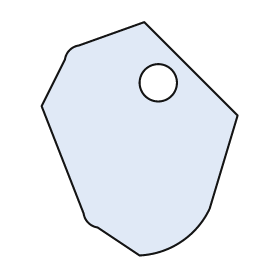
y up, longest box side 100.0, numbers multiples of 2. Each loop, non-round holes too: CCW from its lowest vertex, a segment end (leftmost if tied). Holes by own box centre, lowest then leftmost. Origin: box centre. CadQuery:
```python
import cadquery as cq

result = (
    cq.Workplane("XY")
    .moveTo(0.0, -50.0)
    .threePointArc((18.0, -44.0), (30.0, -30.0))
    .lineTo(42.0, 10.0)
    .lineTo(2.0, 50.0)
    .lineTo(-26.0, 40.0)
    .threePointArc((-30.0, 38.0), (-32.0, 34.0))
    .lineTo(-42.0, 14.0)
    .lineTo(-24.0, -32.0)
    .threePointArc((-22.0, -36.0), (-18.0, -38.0))
    .close()
    .moveTo(8.0, 24.0)
    .circle(8.0)
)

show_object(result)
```